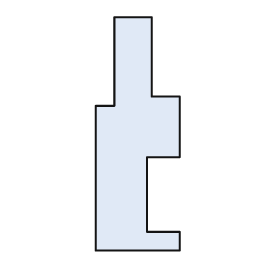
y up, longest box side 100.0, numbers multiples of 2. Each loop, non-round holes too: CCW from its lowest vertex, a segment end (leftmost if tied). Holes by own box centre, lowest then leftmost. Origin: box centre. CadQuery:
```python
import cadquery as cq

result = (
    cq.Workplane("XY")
    .moveTo(-18.0, -50.0)
    .lineTo(18.0, -50.0)
    .lineTo(18.0, -42.0)
    .lineTo(4.0, -42.0)
    .lineTo(4.0, -10.0)
    .lineTo(18.0, -10.0)
    .lineTo(18.0, 16.0)
    .lineTo(6.0, 16.0)
    .lineTo(6.0, 50.0)
    .lineTo(-10.0, 50.0)
    .lineTo(-10.0, 12.0)
    .lineTo(-18.0, 12.0)
    .close()
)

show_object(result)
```